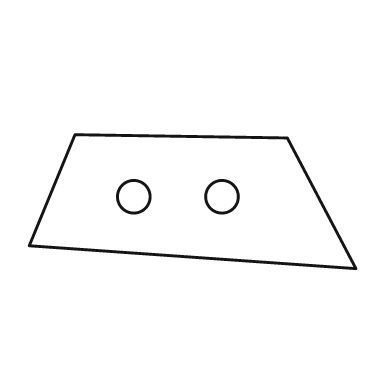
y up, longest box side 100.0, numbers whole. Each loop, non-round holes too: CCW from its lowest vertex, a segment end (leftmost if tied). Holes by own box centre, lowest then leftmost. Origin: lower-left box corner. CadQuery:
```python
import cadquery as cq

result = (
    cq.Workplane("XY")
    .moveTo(100.0, 0.0)
    .lineTo(79.0, 40.0)
    .lineTo(14.0, 41.0)
    .lineTo(0.0, 7.0)
    .close()
    .moveTo(32.0, 22.0)
    .circle(5.0)
    .moveTo(59.0, 22.0)
    .circle(5.0)
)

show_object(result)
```